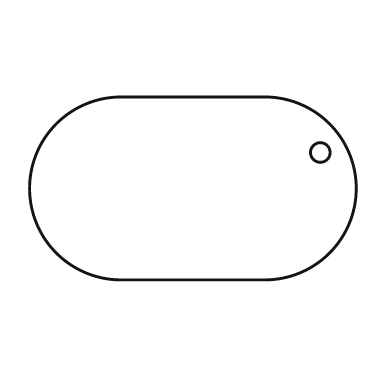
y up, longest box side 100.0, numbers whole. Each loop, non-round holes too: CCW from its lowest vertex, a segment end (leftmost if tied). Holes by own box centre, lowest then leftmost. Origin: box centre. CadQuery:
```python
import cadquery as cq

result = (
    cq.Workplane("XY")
    .moveTo(-22.0, -28.0)
    .lineTo(22.0, -28.0)
    .threePointArc((50.0, 0.0), (22.0, 28.0))
    .lineTo(-22.0, 28.0)
    .threePointArc((-50.0, 0.0), (-22.0, -28.0))
    .close()
    .moveTo(39.0, 11.0)
    .circle(3.0)
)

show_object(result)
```